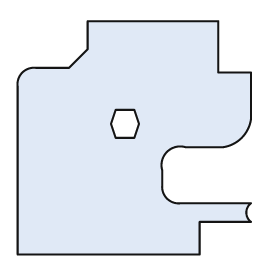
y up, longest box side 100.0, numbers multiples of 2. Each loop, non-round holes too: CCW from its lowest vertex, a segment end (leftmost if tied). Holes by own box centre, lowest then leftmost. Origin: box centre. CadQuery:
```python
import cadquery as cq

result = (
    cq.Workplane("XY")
    .moveTo(-50.0, -50.0)
    .lineTo(28.0, -50.0)
    .lineTo(28.0, -36.0)
    .lineTo(50.0, -36.0)
    .threePointArc((48.0, -32.0), (50.0, -28.0))
    .lineTo(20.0, -28.0)
    .threePointArc((14.0, -26.0), (12.0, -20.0))
    .lineTo(12.0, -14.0)
    .threePointArc((14.0, -6.0), (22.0, -4.0))
    .lineTo(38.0, -4.0)
    .threePointArc((46.0, 0.0), (50.0, 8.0))
    .lineTo(50.0, 28.0)
    .lineTo(36.0, 28.0)
    .lineTo(36.0, 50.0)
    .lineTo(-20.0, 50.0)
    .lineTo(-20.0, 38.0)
    .lineTo(-28.0, 30.0)
    .lineTo(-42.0, 30.0)
    .threePointArc((-48.0, 28.0), (-50.0, 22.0))
    .close()
    .moveTo(-8.0, 0.0)
    .lineTo(0.0, 0.0)
    .lineTo(2.0, 6.0)
    .lineTo(0.0, 12.0)
    .lineTo(-8.0, 12.0)
    .lineTo(-10.0, 6.0)
    .close()
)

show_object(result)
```